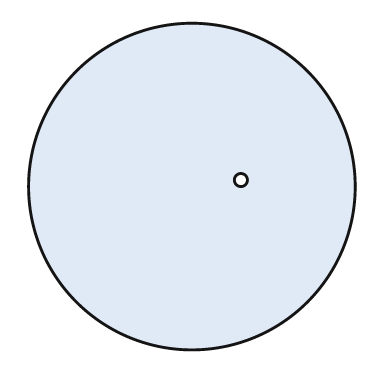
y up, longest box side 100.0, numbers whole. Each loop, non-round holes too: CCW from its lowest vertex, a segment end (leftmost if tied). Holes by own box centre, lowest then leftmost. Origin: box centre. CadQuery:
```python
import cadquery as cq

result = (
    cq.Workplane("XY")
    .moveTo(0.0, 0.0)
    .circle(50.0)
    .moveTo(15.0, 2.0)
    .circle(2.0)
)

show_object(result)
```